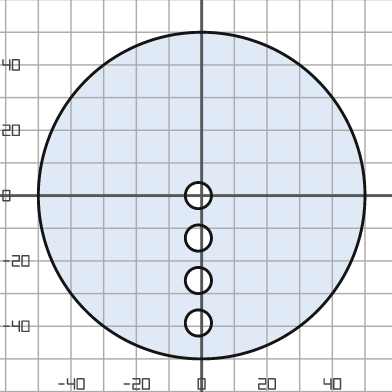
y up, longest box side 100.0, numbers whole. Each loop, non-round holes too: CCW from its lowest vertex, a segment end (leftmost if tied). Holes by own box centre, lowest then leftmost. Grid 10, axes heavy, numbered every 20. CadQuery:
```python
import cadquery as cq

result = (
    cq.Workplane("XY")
    .moveTo(0.0, 0.0)
    .circle(50.0)
    .moveTo(-1.0, -39.0)
    .circle(4.0)
    .moveTo(-1.0, -26.0)
    .circle(4.0)
    .moveTo(-1.0, -13.0)
    .circle(4.0)
    .moveTo(-1.0, 0.0)
    .circle(4.0)
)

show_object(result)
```